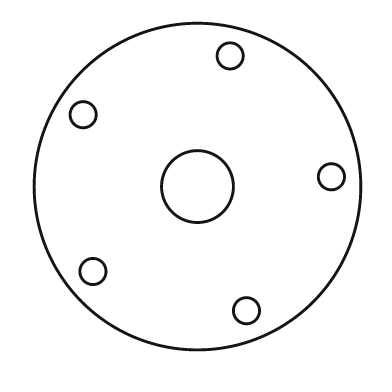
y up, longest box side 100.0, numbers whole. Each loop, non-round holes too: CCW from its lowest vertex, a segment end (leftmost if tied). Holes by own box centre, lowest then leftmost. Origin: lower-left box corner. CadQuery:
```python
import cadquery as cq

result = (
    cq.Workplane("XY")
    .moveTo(50.0, 50.0)
    .circle(50.0)
    .moveTo(65.0, 12.0)
    .circle(4.0)
    .moveTo(18.0, 24.0)
    .circle(4.0)
    .moveTo(50.0, 50.0)
    .circle(11.0)
    .moveTo(91.0, 53.0)
    .circle(4.0)
    .moveTo(15.0, 72.0)
    .circle(4.0)
    .moveTo(60.0, 90.0)
    .circle(4.0)
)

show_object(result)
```